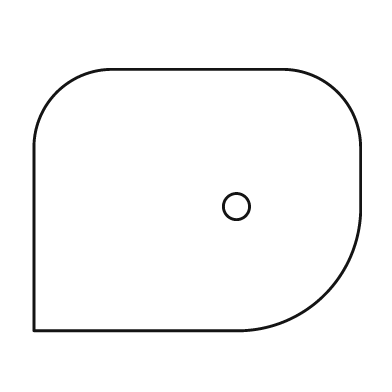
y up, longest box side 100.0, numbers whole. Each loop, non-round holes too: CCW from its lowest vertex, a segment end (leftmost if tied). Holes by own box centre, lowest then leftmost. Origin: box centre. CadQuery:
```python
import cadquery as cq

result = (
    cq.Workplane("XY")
    .moveTo(-50.0, -40.0)
    .lineTo(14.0, -40.0)
    .threePointArc((39.0, -29.0), (50.0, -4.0))
    .lineTo(50.0, 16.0)
    .threePointArc((43.0, 33.0), (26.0, 40.0))
    .lineTo(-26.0, 40.0)
    .threePointArc((-43.0, 33.0), (-50.0, 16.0))
    .close()
    .moveTo(12.0, -2.0)
    .circle(4.0)
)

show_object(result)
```